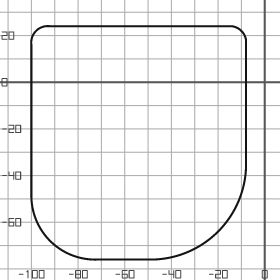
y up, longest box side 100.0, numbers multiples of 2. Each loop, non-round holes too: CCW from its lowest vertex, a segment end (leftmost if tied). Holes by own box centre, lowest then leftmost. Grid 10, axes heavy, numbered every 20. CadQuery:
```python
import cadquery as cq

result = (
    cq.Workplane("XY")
    .moveTo(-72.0, -76.0)
    .lineTo(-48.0, -76.0)
    .threePointArc((-20.0, -64.0), (-8.0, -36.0))
    .lineTo(-8.0, 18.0)
    .threePointArc((-10.0, 22.0), (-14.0, 24.0))
    .lineTo(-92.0, 24.0)
    .threePointArc((-98.0, 22.0), (-100.0, 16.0))
    .lineTo(-100.0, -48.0)
    .threePointArc((-92.0, -68.0), (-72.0, -76.0))
    .close()
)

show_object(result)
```